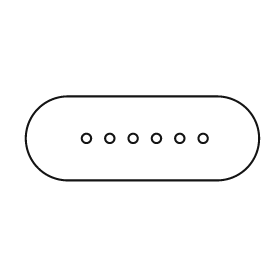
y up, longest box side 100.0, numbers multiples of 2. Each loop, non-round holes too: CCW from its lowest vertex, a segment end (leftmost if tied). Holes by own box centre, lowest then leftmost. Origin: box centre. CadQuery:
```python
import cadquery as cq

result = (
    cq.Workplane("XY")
    .moveTo(-32.0, -18.0)
    .lineTo(32.0, -18.0)
    .threePointArc((50.0, 0.0), (32.0, 18.0))
    .lineTo(-32.0, 18.0)
    .threePointArc((-50.0, 0.0), (-32.0, -18.0))
    .close()
    .moveTo(-24.0, 0.0)
    .circle(2.0)
    .moveTo(-14.0, 0.0)
    .circle(2.0)
    .moveTo(-4.0, 0.0)
    .circle(2.0)
    .moveTo(6.0, 0.0)
    .circle(2.0)
    .moveTo(16.0, 0.0)
    .circle(2.0)
    .moveTo(26.0, 0.0)
    .circle(2.0)
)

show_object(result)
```